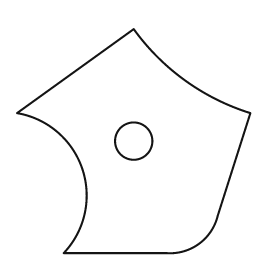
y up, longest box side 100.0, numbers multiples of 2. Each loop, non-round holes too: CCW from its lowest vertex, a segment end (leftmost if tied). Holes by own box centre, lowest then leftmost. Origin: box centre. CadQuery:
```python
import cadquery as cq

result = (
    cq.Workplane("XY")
    .moveTo(-30.0, -48.0)
    .lineTo(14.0, -48.0)
    .threePointArc((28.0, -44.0), (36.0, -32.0))
    .lineTo(50.0, 12.0)
    .threePointArc((22.0, 26.0), (0.0, 48.0))
    .lineTo(-50.0, 12.0)
    .threePointArc((-22.0, -12.0), (-30.0, -48.0))
    .close()
    .moveTo(0.0, 0.0)
    .circle(8.0)
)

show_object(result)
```